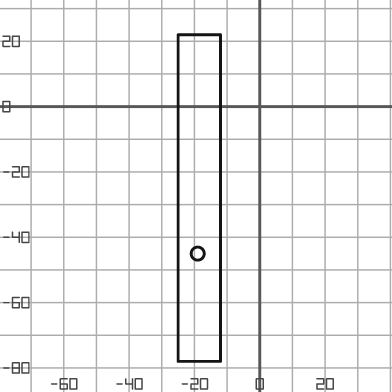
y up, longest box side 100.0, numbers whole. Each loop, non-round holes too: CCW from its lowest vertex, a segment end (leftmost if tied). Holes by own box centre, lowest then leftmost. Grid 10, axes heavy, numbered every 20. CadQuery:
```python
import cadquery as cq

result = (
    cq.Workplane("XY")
    .moveTo(-25.0, -78.0)
    .lineTo(-12.0, -78.0)
    .lineTo(-12.0, 22.0)
    .lineTo(-25.0, 22.0)
    .close()
    .moveTo(-19.0, -45.0)
    .circle(2.0)
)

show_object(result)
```